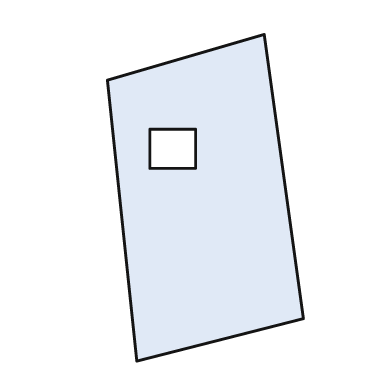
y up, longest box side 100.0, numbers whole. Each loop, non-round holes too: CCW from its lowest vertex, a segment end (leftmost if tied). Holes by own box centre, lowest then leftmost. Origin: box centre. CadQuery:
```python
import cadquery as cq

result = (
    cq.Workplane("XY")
    .moveTo(-21.0, -50.0)
    .lineTo(30.0, -37.0)
    .lineTo(18.0, 50.0)
    .lineTo(-30.0, 36.0)
    .close()
    .moveTo(-17.0, 9.0)
    .lineTo(-3.0, 9.0)
    .lineTo(-3.0, 21.0)
    .lineTo(-17.0, 21.0)
    .close()
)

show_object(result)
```